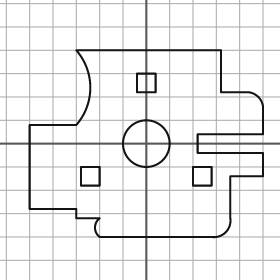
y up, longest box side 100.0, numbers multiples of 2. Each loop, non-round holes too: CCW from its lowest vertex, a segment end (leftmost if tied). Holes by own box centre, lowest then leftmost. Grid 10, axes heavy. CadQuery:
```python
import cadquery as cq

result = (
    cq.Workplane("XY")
    .moveTo(-20.0, -40.0)
    .lineTo(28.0, -40.0)
    .threePointArc((34.0, -38.0), (36.0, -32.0))
    .lineTo(36.0, -14.0)
    .lineTo(50.0, -14.0)
    .lineTo(50.0, -4.0)
    .lineTo(22.0, -4.0)
    .lineTo(22.0, 4.0)
    .lineTo(50.0, 4.0)
    .lineTo(50.0, 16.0)
    .threePointArc((48.0, 20.0), (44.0, 22.0))
    .lineTo(32.0, 22.0)
    .lineTo(32.0, 40.0)
    .lineTo(-30.0, 40.0)
    .threePointArc((-24.0, 24.0), (-30.0, 8.0))
    .lineTo(-50.0, 8.0)
    .lineTo(-50.0, -28.0)
    .lineTo(-30.0, -28.0)
    .lineTo(-30.0, -32.0)
    .lineTo(-20.0, -32.0)
    .threePointArc((-22.0, -36.0), (-20.0, -40.0))
    .close()
    .moveTo(-28.0, -18.0)
    .lineTo(-20.0, -18.0)
    .lineTo(-20.0, -10.0)
    .lineTo(-28.0, -10.0)
    .close()
    .moveTo(20.0, -18.0)
    .lineTo(28.0, -18.0)
    .lineTo(28.0, -10.0)
    .lineTo(20.0, -10.0)
    .close()
    .moveTo(0.0, 0.0)
    .circle(10.0)
    .moveTo(-4.0, 22.0)
    .lineTo(4.0, 22.0)
    .lineTo(4.0, 30.0)
    .lineTo(-4.0, 30.0)
    .close()
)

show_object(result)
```